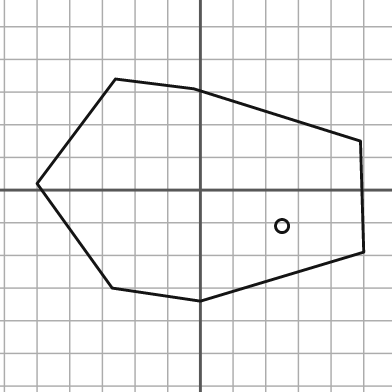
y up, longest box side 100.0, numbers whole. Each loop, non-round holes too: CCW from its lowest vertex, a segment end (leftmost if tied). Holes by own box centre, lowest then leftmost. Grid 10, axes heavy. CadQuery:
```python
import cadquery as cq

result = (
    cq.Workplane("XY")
    .moveTo(0.0, -34.0)
    .lineTo(50.0, -19.0)
    .lineTo(49.0, 15.0)
    .lineTo(-2.0, 31.0)
    .lineTo(-26.0, 34.0)
    .lineTo(-50.0, 2.0)
    .lineTo(-27.0, -30.0)
    .close()
    .moveTo(25.0, -11.0)
    .circle(2.0)
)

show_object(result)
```